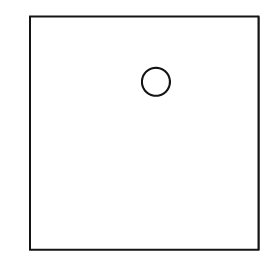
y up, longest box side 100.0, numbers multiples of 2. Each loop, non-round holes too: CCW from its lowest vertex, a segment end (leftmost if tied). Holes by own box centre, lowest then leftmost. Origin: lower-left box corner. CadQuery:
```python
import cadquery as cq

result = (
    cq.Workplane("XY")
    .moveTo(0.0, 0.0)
    .lineTo(98.0, 0.0)
    .lineTo(98.0, 100.0)
    .lineTo(0.0, 100.0)
    .close()
    .moveTo(54.0, 72.0)
    .circle(6.0)
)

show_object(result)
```